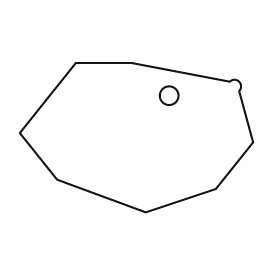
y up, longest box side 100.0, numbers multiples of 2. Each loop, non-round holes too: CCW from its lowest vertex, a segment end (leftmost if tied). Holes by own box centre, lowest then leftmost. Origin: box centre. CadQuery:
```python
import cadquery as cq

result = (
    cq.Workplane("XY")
    .moveTo(4.0, -32.0)
    .lineTo(34.0, -22.0)
    .lineTo(50.0, -2.0)
    .lineTo(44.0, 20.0)
    .threePointArc((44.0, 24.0), (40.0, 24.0))
    .lineTo(-2.0, 32.0)
    .lineTo(-26.0, 32.0)
    .lineTo(-50.0, 2.0)
    .lineTo(-34.0, -18.0)
    .close()
    .moveTo(14.0, 18.0)
    .circle(4.0)
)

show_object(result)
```